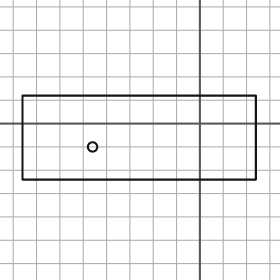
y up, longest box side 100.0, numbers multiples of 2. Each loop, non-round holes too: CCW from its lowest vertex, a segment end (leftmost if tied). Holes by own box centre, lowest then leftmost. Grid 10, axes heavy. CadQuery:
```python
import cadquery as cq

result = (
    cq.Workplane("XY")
    .moveTo(-76.0, -24.0)
    .lineTo(24.0, -24.0)
    .lineTo(24.0, 12.0)
    .lineTo(-76.0, 12.0)
    .close()
    .moveTo(-46.0, -10.0)
    .circle(2.0)
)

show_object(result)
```